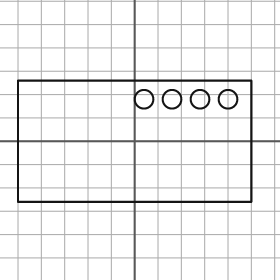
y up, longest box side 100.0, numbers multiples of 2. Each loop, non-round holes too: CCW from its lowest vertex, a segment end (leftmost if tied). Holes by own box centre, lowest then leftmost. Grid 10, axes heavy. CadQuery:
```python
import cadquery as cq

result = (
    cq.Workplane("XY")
    .moveTo(-50.0, -26.0)
    .lineTo(50.0, -26.0)
    .lineTo(50.0, 26.0)
    .lineTo(-50.0, 26.0)
    .close()
    .moveTo(4.0, 18.0)
    .circle(4.0)
    .moveTo(16.0, 18.0)
    .circle(4.0)
    .moveTo(28.0, 18.0)
    .circle(4.0)
    .moveTo(40.0, 18.0)
    .circle(4.0)
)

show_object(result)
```